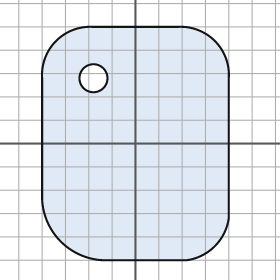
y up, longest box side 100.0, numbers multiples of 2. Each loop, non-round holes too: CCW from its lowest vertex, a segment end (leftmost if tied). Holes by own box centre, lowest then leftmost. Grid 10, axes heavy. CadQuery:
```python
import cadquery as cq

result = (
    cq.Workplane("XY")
    .moveTo(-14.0, -50.0)
    .lineTo(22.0, -50.0)
    .threePointArc((34.0, -44.0), (40.0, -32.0))
    .lineTo(40.0, 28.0)
    .threePointArc((34.0, 44.0), (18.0, 50.0))
    .lineTo(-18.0, 50.0)
    .threePointArc((-34.0, 44.0), (-40.0, 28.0))
    .lineTo(-40.0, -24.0)
    .threePointArc((-32.0, -42.0), (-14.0, -50.0))
    .close()
    .moveTo(-18.0, 28.0)
    .circle(6.0)
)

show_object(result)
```